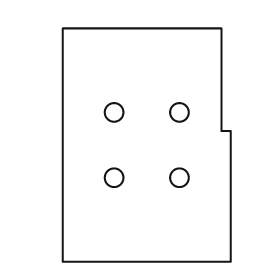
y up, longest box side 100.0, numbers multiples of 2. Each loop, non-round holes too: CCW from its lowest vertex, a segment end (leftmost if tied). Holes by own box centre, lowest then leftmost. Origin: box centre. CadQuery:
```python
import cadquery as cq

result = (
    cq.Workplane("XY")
    .moveTo(-36.0, -50.0)
    .lineTo(36.0, -50.0)
    .lineTo(36.0, 6.0)
    .lineTo(32.0, 6.0)
    .lineTo(32.0, 50.0)
    .lineTo(-36.0, 50.0)
    .close()
    .moveTo(-14.0, -14.0)
    .circle(4.0)
    .moveTo(14.0, -14.0)
    .circle(4.0)
    .moveTo(-14.0, 14.0)
    .circle(4.0)
    .moveTo(14.0, 14.0)
    .circle(4.0)
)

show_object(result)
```